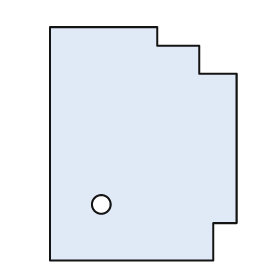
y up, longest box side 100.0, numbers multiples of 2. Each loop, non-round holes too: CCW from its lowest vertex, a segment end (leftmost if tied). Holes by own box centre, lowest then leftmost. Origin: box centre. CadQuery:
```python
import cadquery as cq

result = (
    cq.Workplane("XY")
    .moveTo(-40.0, -50.0)
    .lineTo(30.0, -50.0)
    .lineTo(30.0, -34.0)
    .lineTo(40.0, -34.0)
    .lineTo(40.0, 30.0)
    .lineTo(24.0, 30.0)
    .lineTo(24.0, 42.0)
    .lineTo(6.0, 42.0)
    .lineTo(6.0, 50.0)
    .lineTo(-40.0, 50.0)
    .close()
    .moveTo(-18.0, -26.0)
    .circle(4.0)
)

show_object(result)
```